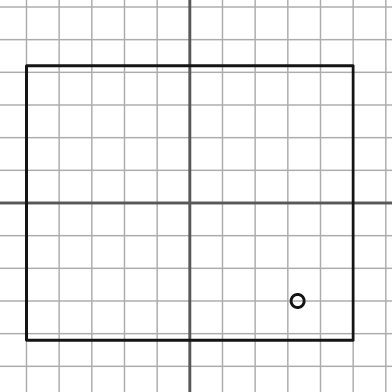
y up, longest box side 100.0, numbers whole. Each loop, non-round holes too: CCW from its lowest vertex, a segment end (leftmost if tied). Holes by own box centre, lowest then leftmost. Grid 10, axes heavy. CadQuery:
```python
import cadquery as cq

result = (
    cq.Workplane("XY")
    .moveTo(-50.0, -42.0)
    .lineTo(50.0, -42.0)
    .lineTo(50.0, 42.0)
    .lineTo(-50.0, 42.0)
    .close()
    .moveTo(33.0, -30.0)
    .circle(2.0)
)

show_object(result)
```